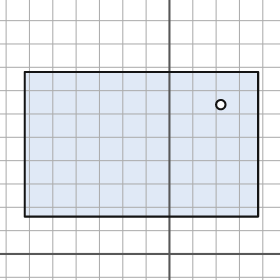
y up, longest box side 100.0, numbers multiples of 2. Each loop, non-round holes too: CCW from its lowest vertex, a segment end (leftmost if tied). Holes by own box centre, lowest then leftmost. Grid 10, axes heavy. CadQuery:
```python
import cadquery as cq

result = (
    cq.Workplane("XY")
    .moveTo(-62.0, 16.0)
    .lineTo(38.0, 16.0)
    .lineTo(38.0, 78.0)
    .lineTo(-62.0, 78.0)
    .close()
    .moveTo(22.0, 64.0)
    .circle(2.0)
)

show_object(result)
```